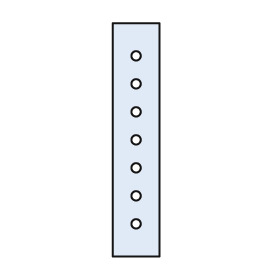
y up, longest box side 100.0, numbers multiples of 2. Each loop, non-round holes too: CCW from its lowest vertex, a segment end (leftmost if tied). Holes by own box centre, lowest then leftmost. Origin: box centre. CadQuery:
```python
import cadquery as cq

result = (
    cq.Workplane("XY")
    .moveTo(-10.0, -50.0)
    .lineTo(10.0, -50.0)
    .lineTo(10.0, 50.0)
    .lineTo(-10.0, 50.0)
    .close()
    .moveTo(0.0, -36.0)
    .circle(2.0)
    .moveTo(0.0, -24.0)
    .circle(2.0)
    .moveTo(0.0, -12.0)
    .circle(2.0)
    .moveTo(0.0, 0.0)
    .circle(2.0)
    .moveTo(0.0, 12.0)
    .circle(2.0)
    .moveTo(0.0, 24.0)
    .circle(2.0)
    .moveTo(0.0, 36.0)
    .circle(2.0)
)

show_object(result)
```